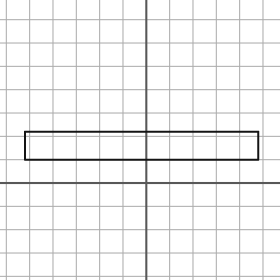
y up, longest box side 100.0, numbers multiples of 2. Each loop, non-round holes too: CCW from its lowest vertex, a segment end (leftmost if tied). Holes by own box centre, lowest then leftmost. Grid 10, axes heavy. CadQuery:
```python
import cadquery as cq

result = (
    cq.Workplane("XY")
    .moveTo(-52.0, 10.0)
    .lineTo(48.0, 10.0)
    .lineTo(48.0, 22.0)
    .lineTo(-52.0, 22.0)
    .close()
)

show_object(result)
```